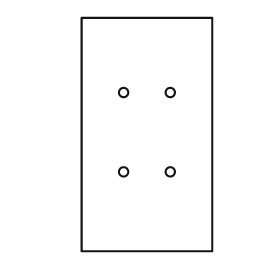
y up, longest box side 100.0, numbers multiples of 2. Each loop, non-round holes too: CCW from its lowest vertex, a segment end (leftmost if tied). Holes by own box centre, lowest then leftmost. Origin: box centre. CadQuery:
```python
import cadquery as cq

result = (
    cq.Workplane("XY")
    .moveTo(-28.0, -50.0)
    .lineTo(28.0, -50.0)
    .lineTo(28.0, 50.0)
    .lineTo(-28.0, 50.0)
    .close()
    .moveTo(-10.0, -16.0)
    .circle(2.0)
    .moveTo(10.0, -16.0)
    .circle(2.0)
    .moveTo(-10.0, 18.0)
    .circle(2.0)
    .moveTo(10.0, 18.0)
    .circle(2.0)
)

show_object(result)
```